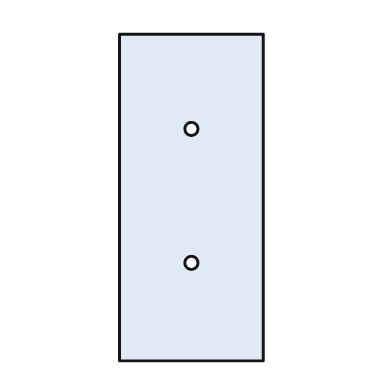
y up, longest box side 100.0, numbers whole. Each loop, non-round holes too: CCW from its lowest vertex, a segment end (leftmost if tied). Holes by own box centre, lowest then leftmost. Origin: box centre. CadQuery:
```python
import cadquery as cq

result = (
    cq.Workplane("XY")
    .moveTo(-22.0, -50.0)
    .lineTo(22.0, -50.0)
    .lineTo(22.0, 50.0)
    .lineTo(-22.0, 50.0)
    .close()
    .moveTo(0.0, -20.0)
    .circle(2.0)
    .moveTo(0.0, 21.0)
    .circle(2.0)
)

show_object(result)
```